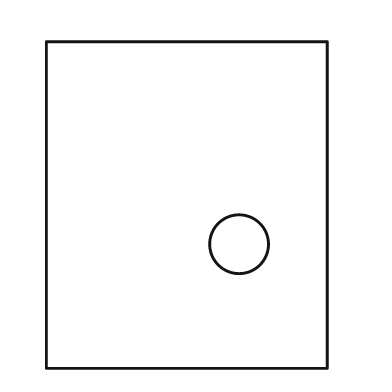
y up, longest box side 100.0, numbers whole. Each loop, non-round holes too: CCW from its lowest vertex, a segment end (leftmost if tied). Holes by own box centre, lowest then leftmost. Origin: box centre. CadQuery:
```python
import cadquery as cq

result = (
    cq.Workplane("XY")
    .moveTo(-43.0, -50.0)
    .lineTo(43.0, -50.0)
    .lineTo(43.0, 50.0)
    .lineTo(-43.0, 50.0)
    .close()
    .moveTo(16.0, -12.0)
    .circle(9.0)
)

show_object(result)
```